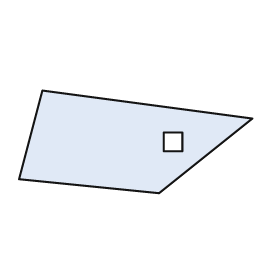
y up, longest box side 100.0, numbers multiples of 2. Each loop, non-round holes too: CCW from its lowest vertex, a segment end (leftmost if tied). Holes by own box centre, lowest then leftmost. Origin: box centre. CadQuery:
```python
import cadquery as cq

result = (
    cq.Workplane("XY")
    .moveTo(10.0, -22.0)
    .lineTo(50.0, 10.0)
    .lineTo(-40.0, 22.0)
    .lineTo(-50.0, -16.0)
    .close()
    .moveTo(12.0, -4.0)
    .lineTo(20.0, -4.0)
    .lineTo(20.0, 4.0)
    .lineTo(12.0, 4.0)
    .close()
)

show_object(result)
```